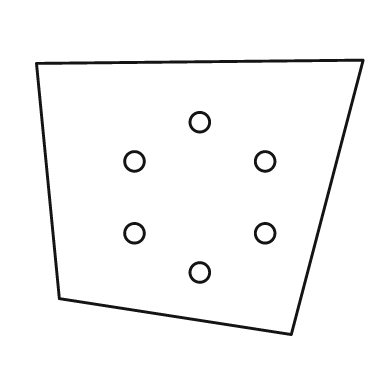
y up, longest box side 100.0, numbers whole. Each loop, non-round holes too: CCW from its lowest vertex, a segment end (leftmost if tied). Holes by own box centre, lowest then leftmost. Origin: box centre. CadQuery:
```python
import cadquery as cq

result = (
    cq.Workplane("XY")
    .moveTo(28.0, -42.0)
    .lineTo(50.0, 42.0)
    .lineTo(-50.0, 41.0)
    .lineTo(-43.0, -31.0)
    .close()
    .moveTo(0.0, -23.0)
    .circle(3.0)
    .moveTo(-20.0, -11.0)
    .circle(3.0)
    .moveTo(20.0, -11.0)
    .circle(3.0)
    .moveTo(-20.0, 11.0)
    .circle(3.0)
    .moveTo(20.0, 11.0)
    .circle(3.0)
    .moveTo(0.0, 23.0)
    .circle(3.0)
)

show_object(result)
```